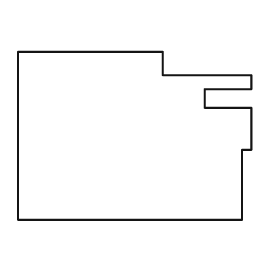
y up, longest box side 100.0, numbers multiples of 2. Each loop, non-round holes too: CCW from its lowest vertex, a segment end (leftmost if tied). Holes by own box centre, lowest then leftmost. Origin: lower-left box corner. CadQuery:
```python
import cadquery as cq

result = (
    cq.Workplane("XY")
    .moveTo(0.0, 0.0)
    .lineTo(96.0, 0.0)
    .lineTo(96.0, 30.0)
    .lineTo(100.0, 30.0)
    .lineTo(100.0, 48.0)
    .lineTo(80.0, 48.0)
    .lineTo(80.0, 56.0)
    .lineTo(100.0, 56.0)
    .lineTo(100.0, 62.0)
    .lineTo(62.0, 62.0)
    .lineTo(62.0, 72.0)
    .lineTo(0.0, 72.0)
    .close()
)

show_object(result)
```